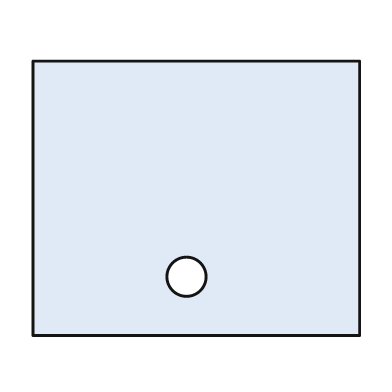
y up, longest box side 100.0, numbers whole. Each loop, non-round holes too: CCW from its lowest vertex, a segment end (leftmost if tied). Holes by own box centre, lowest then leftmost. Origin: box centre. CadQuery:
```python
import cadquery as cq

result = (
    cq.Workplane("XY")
    .moveTo(-50.0, -42.0)
    .lineTo(50.0, -42.0)
    .lineTo(50.0, 42.0)
    .lineTo(-50.0, 42.0)
    .close()
    .moveTo(-3.0, -24.0)
    .circle(6.0)
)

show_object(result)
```